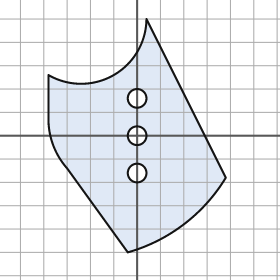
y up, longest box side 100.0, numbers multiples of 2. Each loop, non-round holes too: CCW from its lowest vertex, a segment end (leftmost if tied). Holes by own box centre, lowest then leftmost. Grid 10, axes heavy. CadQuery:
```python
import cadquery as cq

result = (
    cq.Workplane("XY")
    .moveTo(-4.0, -50.0)
    .threePointArc((20.0, -38.0), (38.0, -18.0))
    .lineTo(4.0, 50.0)
    .threePointArc((-10.0, 26.0), (-38.0, 26.0))
    .lineTo(-38.0, 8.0)
    .threePointArc((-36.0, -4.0), (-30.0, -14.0))
    .close()
    .moveTo(0.0, -16.0)
    .circle(4.0)
    .moveTo(0.0, 0.0)
    .circle(4.0)
    .moveTo(0.0, 16.0)
    .circle(4.0)
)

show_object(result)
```